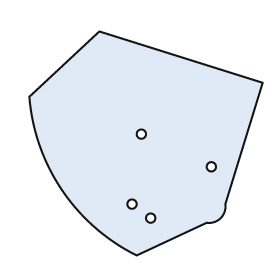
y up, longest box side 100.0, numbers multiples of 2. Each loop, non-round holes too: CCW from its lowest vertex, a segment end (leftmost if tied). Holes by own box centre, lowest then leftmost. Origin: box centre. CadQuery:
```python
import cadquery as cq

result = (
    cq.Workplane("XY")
    .moveTo(-4.0, -48.0)
    .lineTo(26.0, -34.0)
    .threePointArc((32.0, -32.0), (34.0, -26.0))
    .lineTo(50.0, 26.0)
    .lineTo(-20.0, 48.0)
    .lineTo(-50.0, 20.0)
    .threePointArc((-36.0, -20.0), (-4.0, -48.0))
    .close()
    .moveTo(2.0, -32.0)
    .circle(2.0)
    .moveTo(-6.0, -26.0)
    .circle(2.0)
    .moveTo(28.0, -10.0)
    .circle(2.0)
    .moveTo(-2.0, 4.0)
    .circle(2.0)
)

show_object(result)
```